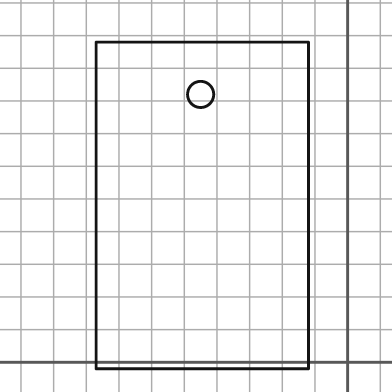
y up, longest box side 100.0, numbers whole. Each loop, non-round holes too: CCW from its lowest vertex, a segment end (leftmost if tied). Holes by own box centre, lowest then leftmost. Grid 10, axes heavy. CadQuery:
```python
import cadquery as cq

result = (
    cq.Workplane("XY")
    .moveTo(-77.0, -2.0)
    .lineTo(-12.0, -2.0)
    .lineTo(-12.0, 98.0)
    .lineTo(-77.0, 98.0)
    .close()
    .moveTo(-45.0, 82.0)
    .circle(4.0)
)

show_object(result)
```